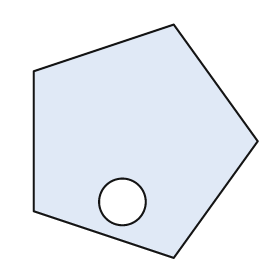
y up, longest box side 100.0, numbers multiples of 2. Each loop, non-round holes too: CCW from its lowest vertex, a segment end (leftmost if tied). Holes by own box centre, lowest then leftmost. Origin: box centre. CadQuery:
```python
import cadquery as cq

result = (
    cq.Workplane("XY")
    .moveTo(12.0, -50.0)
    .lineTo(48.0, 0.0)
    .lineTo(12.0, 50.0)
    .lineTo(-48.0, 30.0)
    .lineTo(-48.0, -30.0)
    .close()
    .moveTo(-10.0, -26.0)
    .circle(10.0)
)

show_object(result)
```